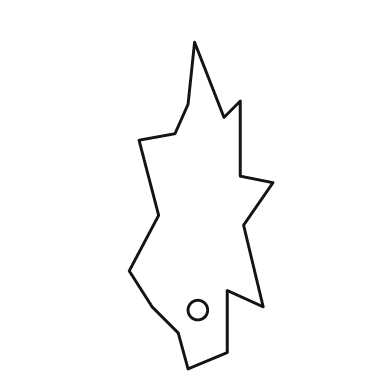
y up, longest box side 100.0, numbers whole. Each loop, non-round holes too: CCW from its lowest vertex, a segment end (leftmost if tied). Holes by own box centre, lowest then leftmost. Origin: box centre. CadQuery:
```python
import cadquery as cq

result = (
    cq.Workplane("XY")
    .moveTo(-4.0, -50.0)
    .lineTo(8.0, -45.0)
    .lineTo(8.0, -26.0)
    .lineTo(19.0, -31.0)
    .lineTo(13.0, -6.0)
    .lineTo(22.0, 7.0)
    .lineTo(12.0, 9.0)
    .lineTo(12.0, 32.0)
    .lineTo(7.0, 27.0)
    .lineTo(-2.0, 50.0)
    .lineTo(-4.0, 31.0)
    .lineTo(-8.0, 22.0)
    .lineTo(-19.0, 20.0)
    .lineTo(-13.0, -3.0)
    .lineTo(-22.0, -20.0)
    .lineTo(-15.0, -31.0)
    .lineTo(-7.0, -39.0)
    .close()
    .moveTo(-1.0, -32.0)
    .circle(3.0)
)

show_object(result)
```